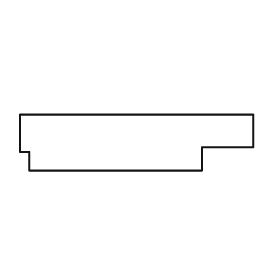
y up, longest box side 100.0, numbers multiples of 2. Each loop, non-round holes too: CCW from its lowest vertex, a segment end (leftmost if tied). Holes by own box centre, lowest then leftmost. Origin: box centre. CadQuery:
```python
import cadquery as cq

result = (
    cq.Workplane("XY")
    .moveTo(-46.0, -12.0)
    .lineTo(28.0, -12.0)
    .lineTo(28.0, -2.0)
    .lineTo(50.0, -2.0)
    .lineTo(50.0, 12.0)
    .lineTo(-50.0, 12.0)
    .lineTo(-50.0, -4.0)
    .lineTo(-46.0, -4.0)
    .close()
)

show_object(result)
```